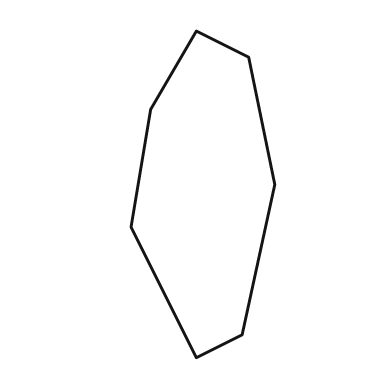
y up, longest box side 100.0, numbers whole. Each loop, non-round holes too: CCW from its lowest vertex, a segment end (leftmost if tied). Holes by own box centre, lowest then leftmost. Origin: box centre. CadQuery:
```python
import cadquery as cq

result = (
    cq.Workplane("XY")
    .moveTo(-2.0, -50.0)
    .lineTo(12.0, -43.0)
    .lineTo(22.0, 3.0)
    .lineTo(14.0, 42.0)
    .lineTo(-2.0, 50.0)
    .lineTo(-16.0, 26.0)
    .lineTo(-22.0, -10.0)
    .close()
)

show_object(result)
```